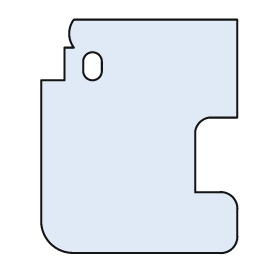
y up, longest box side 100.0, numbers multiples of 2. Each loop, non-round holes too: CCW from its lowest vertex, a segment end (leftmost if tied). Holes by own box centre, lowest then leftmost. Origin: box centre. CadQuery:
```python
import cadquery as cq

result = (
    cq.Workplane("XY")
    .moveTo(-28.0, -50.0)
    .lineTo(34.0, -50.0)
    .threePointArc((40.0, -48.0), (42.0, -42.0))
    .lineTo(42.0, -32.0)
    .threePointArc((40.0, -26.0), (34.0, -24.0))
    .lineTo(24.0, -24.0)
    .lineTo(24.0, 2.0)
    .threePointArc((26.0, 6.0), (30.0, 8.0))
    .lineTo(42.0, 8.0)
    .lineTo(42.0, 50.0)
    .lineTo(-28.0, 50.0)
    .threePointArc((-30.0, 44.0), (-28.0, 38.0))
    .lineTo(-32.0, 38.0)
    .lineTo(-32.0, 24.0)
    .lineTo(-42.0, 24.0)
    .lineTo(-42.0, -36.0)
    .threePointArc((-38.0, -46.0), (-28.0, -50.0))
    .close()
    .moveTo(-24.0, 28.0)
    .threePointArc((-20.0, 24.0), (-16.0, 28.0))
    .lineTo(-16.0, 32.0)
    .threePointArc((-20.0, 36.0), (-24.0, 32.0))
    .close()
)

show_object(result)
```